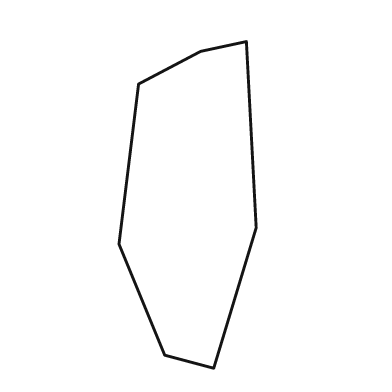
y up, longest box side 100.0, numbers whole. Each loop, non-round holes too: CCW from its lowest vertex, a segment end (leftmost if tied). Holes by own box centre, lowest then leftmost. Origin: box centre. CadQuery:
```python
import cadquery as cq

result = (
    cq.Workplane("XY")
    .moveTo(8.0, -50.0)
    .lineTo(21.0, -7.0)
    .lineTo(18.0, 50.0)
    .lineTo(4.0, 47.0)
    .lineTo(-15.0, 37.0)
    .lineTo(-21.0, -12.0)
    .lineTo(-7.0, -46.0)
    .close()
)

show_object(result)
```